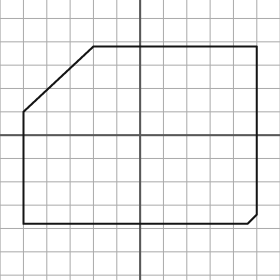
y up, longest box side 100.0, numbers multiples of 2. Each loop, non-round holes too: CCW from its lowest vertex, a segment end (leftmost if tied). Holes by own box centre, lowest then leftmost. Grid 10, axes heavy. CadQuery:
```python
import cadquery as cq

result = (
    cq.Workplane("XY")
    .moveTo(-50.0, -38.0)
    .lineTo(46.0, -38.0)
    .lineTo(50.0, -34.0)
    .lineTo(50.0, 38.0)
    .lineTo(-20.0, 38.0)
    .lineTo(-50.0, 10.0)
    .close()
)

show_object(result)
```